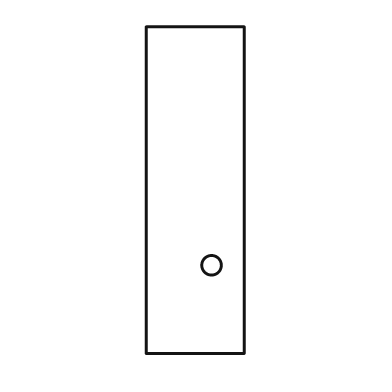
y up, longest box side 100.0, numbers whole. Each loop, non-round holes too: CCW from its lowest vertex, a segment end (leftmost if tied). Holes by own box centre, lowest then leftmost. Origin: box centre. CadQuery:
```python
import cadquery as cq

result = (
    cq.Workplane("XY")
    .moveTo(-15.0, -50.0)
    .lineTo(15.0, -50.0)
    .lineTo(15.0, 50.0)
    .lineTo(-15.0, 50.0)
    .close()
    .moveTo(5.0, -23.0)
    .circle(3.0)
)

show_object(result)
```